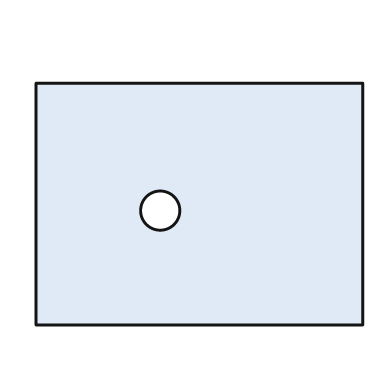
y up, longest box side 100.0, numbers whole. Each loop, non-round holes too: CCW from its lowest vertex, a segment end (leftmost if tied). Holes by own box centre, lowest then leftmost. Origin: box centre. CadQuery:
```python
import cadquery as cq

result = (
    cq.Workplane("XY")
    .moveTo(-50.0, -37.0)
    .lineTo(50.0, -37.0)
    .lineTo(50.0, 37.0)
    .lineTo(-50.0, 37.0)
    .close()
    .moveTo(-12.0, -2.0)
    .circle(6.0)
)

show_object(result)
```